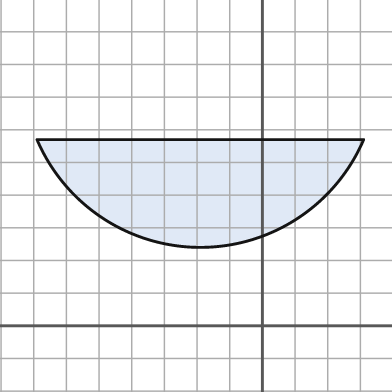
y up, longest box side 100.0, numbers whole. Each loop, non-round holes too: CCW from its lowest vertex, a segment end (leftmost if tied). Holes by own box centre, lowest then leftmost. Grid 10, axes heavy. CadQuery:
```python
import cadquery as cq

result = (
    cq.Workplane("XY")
    .moveTo(-69.0, 57.0)
    .threePointArc((-19.0, 24.0), (31.0, 57.0))
    .close()
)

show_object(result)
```